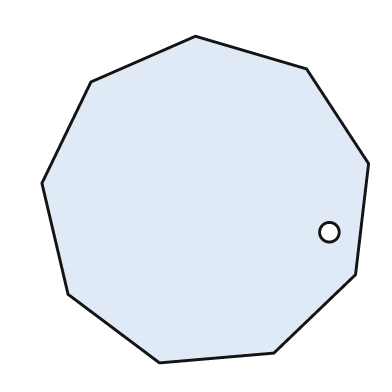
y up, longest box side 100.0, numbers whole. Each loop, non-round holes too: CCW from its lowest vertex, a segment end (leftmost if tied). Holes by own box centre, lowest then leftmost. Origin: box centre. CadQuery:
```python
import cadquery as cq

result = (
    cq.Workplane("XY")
    .moveTo(-14.0, -50.0)
    .lineTo(21.0, -47.0)
    .lineTo(46.0, -23.0)
    .lineTo(50.0, 11.0)
    .lineTo(31.0, 40.0)
    .lineTo(-3.0, 50.0)
    .lineTo(-35.0, 36.0)
    .lineTo(-50.0, 5.0)
    .lineTo(-42.0, -29.0)
    .close()
    .moveTo(38.0, -10.0)
    .circle(3.0)
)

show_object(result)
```